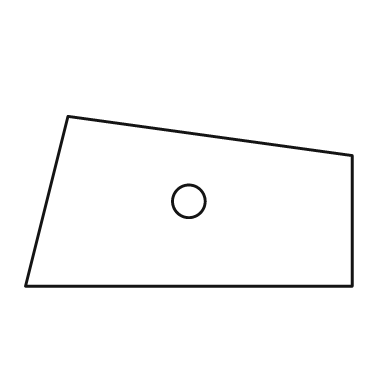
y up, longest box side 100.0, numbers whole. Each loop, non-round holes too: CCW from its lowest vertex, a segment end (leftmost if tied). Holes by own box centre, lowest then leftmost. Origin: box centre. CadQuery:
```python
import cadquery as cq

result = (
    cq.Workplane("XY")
    .moveTo(-50.0, -26.0)
    .lineTo(50.0, -26.0)
    .lineTo(50.0, 14.0)
    .lineTo(-37.0, 26.0)
    .close()
    .moveTo(0.0, 0.0)
    .circle(5.0)
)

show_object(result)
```